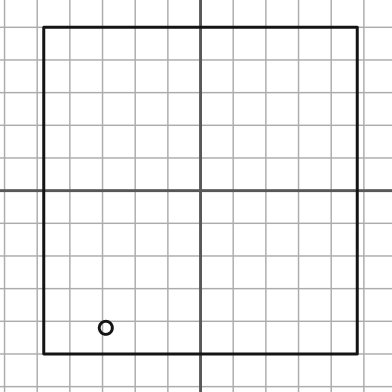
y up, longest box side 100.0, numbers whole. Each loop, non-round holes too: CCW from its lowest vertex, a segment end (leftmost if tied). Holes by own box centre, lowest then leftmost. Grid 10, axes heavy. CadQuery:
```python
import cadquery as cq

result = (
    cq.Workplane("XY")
    .moveTo(-48.0, -50.0)
    .lineTo(48.0, -50.0)
    .lineTo(48.0, 50.0)
    .lineTo(-48.0, 50.0)
    .close()
    .moveTo(-29.0, -42.0)
    .circle(2.0)
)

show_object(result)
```